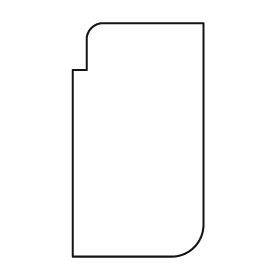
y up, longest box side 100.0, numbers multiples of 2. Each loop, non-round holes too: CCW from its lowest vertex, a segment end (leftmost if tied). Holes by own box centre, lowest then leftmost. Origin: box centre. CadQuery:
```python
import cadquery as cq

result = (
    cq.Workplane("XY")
    .moveTo(-28.0, -50.0)
    .lineTo(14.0, -50.0)
    .threePointArc((24.0, -46.0), (28.0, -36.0))
    .lineTo(28.0, 50.0)
    .lineTo(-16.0, 50.0)
    .threePointArc((-20.0, 48.0), (-22.0, 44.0))
    .lineTo(-22.0, 30.0)
    .lineTo(-28.0, 30.0)
    .close()
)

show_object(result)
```